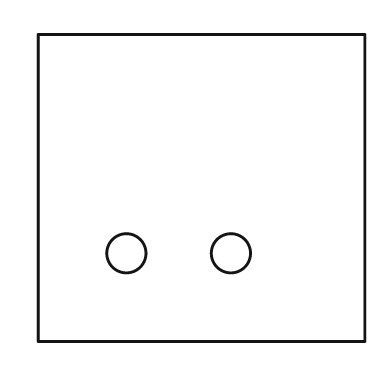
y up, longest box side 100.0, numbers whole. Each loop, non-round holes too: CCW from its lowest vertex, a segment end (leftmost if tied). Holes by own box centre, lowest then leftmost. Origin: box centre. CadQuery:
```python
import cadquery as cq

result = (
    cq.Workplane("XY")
    .moveTo(-50.0, -47.0)
    .lineTo(50.0, -47.0)
    .lineTo(50.0, 47.0)
    .lineTo(-50.0, 47.0)
    .close()
    .moveTo(-23.0, -20.0)
    .circle(6.0)
    .moveTo(9.0, -20.0)
    .circle(6.0)
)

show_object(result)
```